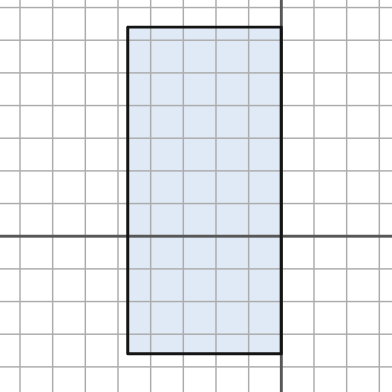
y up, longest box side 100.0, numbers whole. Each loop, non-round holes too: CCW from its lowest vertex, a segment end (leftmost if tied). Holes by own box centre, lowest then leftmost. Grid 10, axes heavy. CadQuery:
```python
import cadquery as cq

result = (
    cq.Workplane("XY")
    .moveTo(-47.0, -36.0)
    .lineTo(0.0, -36.0)
    .lineTo(0.0, 64.0)
    .lineTo(-47.0, 64.0)
    .close()
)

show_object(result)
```